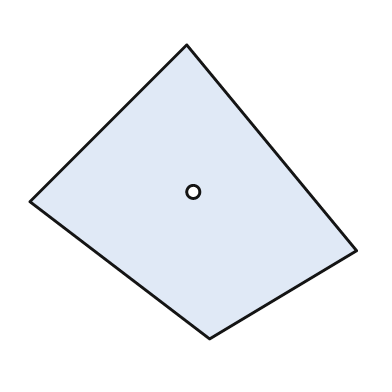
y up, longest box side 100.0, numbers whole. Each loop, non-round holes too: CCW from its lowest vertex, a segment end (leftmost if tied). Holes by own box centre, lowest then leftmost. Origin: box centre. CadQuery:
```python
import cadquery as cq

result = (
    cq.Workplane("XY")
    .moveTo(5.0, -45.0)
    .lineTo(50.0, -18.0)
    .lineTo(-2.0, 45.0)
    .lineTo(-50.0, -3.0)
    .close()
    .moveTo(0.0, 0.0)
    .circle(2.0)
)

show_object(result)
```